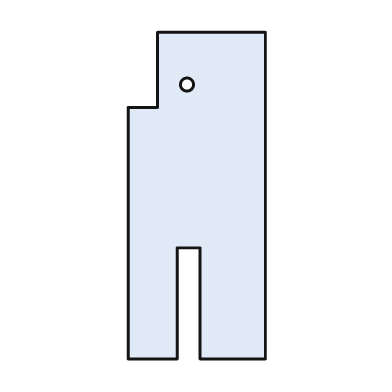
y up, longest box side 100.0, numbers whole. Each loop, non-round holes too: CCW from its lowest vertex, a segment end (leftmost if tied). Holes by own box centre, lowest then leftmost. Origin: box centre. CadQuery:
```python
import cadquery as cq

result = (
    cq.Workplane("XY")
    .moveTo(-21.0, -50.0)
    .lineTo(-6.0, -50.0)
    .lineTo(-6.0, -16.0)
    .lineTo(1.0, -16.0)
    .lineTo(1.0, -50.0)
    .lineTo(21.0, -50.0)
    .lineTo(21.0, 50.0)
    .lineTo(-12.0, 50.0)
    .lineTo(-12.0, 27.0)
    .lineTo(-21.0, 27.0)
    .close()
    .moveTo(-3.0, 34.0)
    .circle(2.0)
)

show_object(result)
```